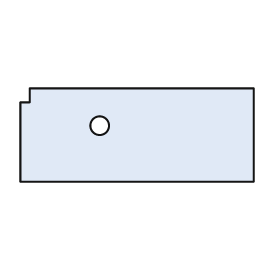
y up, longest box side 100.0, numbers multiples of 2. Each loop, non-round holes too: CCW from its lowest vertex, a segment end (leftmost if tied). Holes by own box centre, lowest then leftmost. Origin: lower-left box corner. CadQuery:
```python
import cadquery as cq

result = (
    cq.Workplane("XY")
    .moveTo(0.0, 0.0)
    .lineTo(100.0, 0.0)
    .lineTo(100.0, 40.0)
    .lineTo(4.0, 40.0)
    .lineTo(4.0, 34.0)
    .lineTo(0.0, 34.0)
    .close()
    .moveTo(34.0, 24.0)
    .circle(4.0)
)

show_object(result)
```